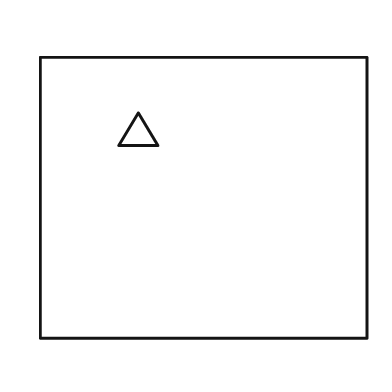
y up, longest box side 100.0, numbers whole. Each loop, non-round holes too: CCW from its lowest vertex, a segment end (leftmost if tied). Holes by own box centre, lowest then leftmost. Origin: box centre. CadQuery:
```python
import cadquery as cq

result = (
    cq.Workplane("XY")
    .moveTo(-50.0, -43.0)
    .lineTo(50.0, -43.0)
    .lineTo(50.0, 43.0)
    .lineTo(-50.0, 43.0)
    .close()
    .moveTo(-26.0, 16.0)
    .lineTo(-14.0, 16.0)
    .lineTo(-20.0, 26.0)
    .close()
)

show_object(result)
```